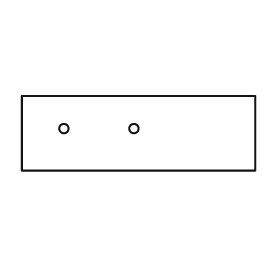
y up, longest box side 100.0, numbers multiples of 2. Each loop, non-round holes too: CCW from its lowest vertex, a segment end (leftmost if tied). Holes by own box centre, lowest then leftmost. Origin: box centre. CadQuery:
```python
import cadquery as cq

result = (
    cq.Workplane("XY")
    .moveTo(-50.0, -16.0)
    .lineTo(50.0, -16.0)
    .lineTo(50.0, 16.0)
    .lineTo(-50.0, 16.0)
    .close()
    .moveTo(-32.0, 2.0)
    .circle(2.0)
    .moveTo(-2.0, 2.0)
    .circle(2.0)
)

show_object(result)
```